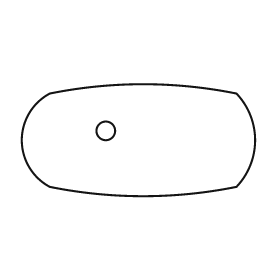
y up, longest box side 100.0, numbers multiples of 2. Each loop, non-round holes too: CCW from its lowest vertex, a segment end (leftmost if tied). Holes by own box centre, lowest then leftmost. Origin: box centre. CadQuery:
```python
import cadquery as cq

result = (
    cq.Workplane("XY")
    .moveTo(-38.0, -20.0)
    .threePointArc((2.0, -24.0), (42.0, -20.0))
    .threePointArc((50.0, 0.0), (42.0, 20.0))
    .threePointArc((2.0, 24.0), (-38.0, 20.0))
    .threePointArc((-50.0, 0.0), (-38.0, -20.0))
    .close()
    .moveTo(-14.0, 4.0)
    .circle(4.0)
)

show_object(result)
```